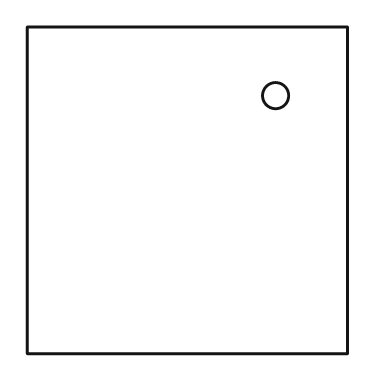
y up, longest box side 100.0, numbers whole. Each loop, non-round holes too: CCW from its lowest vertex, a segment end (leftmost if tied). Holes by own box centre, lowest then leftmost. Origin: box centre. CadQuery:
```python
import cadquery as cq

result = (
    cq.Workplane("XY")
    .moveTo(-49.0, -50.0)
    .lineTo(49.0, -50.0)
    .lineTo(49.0, 50.0)
    .lineTo(-49.0, 50.0)
    .close()
    .moveTo(27.0, 29.0)
    .circle(4.0)
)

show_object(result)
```